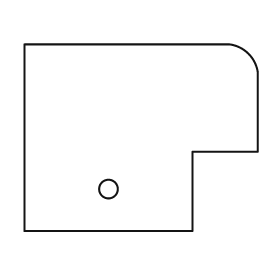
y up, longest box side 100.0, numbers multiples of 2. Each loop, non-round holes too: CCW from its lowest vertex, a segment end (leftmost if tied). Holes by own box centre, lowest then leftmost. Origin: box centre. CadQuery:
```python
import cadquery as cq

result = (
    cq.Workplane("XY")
    .moveTo(-50.0, -40.0)
    .lineTo(22.0, -40.0)
    .lineTo(22.0, -6.0)
    .lineTo(50.0, -6.0)
    .lineTo(50.0, 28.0)
    .threePointArc((46.0, 36.0), (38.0, 40.0))
    .lineTo(-50.0, 40.0)
    .close()
    .moveTo(-14.0, -22.0)
    .circle(4.0)
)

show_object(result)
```